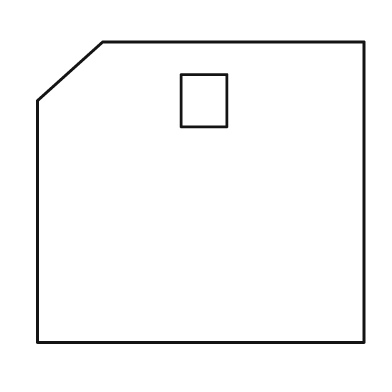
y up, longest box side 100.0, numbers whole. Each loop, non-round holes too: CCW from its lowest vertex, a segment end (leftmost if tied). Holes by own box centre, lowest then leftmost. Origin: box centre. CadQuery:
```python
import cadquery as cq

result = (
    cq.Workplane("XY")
    .moveTo(-50.0, -46.0)
    .lineTo(50.0, -46.0)
    .lineTo(50.0, 46.0)
    .lineTo(-30.0, 46.0)
    .lineTo(-50.0, 28.0)
    .close()
    .moveTo(-6.0, 20.0)
    .lineTo(8.0, 20.0)
    .lineTo(8.0, 36.0)
    .lineTo(-6.0, 36.0)
    .close()
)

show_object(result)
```